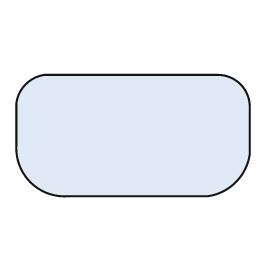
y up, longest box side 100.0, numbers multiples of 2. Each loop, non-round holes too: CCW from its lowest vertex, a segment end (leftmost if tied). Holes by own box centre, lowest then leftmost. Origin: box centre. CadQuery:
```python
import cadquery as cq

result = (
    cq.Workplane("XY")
    .moveTo(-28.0, -26.0)
    .lineTo(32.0, -26.0)
    .threePointArc((44.0, -20.0), (50.0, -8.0))
    .lineTo(50.0, 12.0)
    .threePointArc((46.0, 22.0), (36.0, 26.0))
    .lineTo(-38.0, 26.0)
    .threePointArc((-46.0, 22.0), (-50.0, 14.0))
    .lineTo(-50.0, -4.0)
    .threePointArc((-44.0, -20.0), (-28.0, -26.0))
    .close()
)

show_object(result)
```